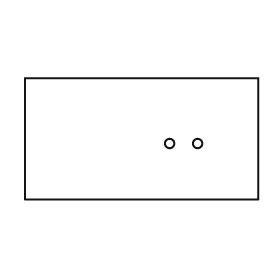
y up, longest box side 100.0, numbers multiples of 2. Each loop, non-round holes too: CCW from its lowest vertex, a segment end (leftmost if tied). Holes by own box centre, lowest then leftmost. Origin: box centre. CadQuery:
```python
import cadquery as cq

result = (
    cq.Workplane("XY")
    .moveTo(-50.0, -26.0)
    .lineTo(50.0, -26.0)
    .lineTo(50.0, 26.0)
    .lineTo(-50.0, 26.0)
    .close()
    .moveTo(12.0, -2.0)
    .circle(2.0)
    .moveTo(24.0, -2.0)
    .circle(2.0)
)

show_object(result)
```